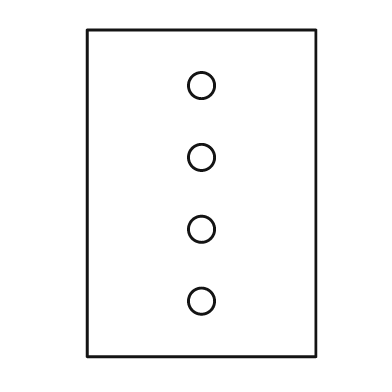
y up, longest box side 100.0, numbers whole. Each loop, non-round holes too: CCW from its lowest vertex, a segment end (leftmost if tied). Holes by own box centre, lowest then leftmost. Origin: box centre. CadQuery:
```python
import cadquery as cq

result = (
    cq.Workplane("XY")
    .moveTo(-35.0, -50.0)
    .lineTo(35.0, -50.0)
    .lineTo(35.0, 50.0)
    .lineTo(-35.0, 50.0)
    .close()
    .moveTo(0.0, -33.0)
    .circle(4.0)
    .moveTo(0.0, -11.0)
    .circle(4.0)
    .moveTo(0.0, 11.0)
    .circle(4.0)
    .moveTo(0.0, 33.0)
    .circle(4.0)
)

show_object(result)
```